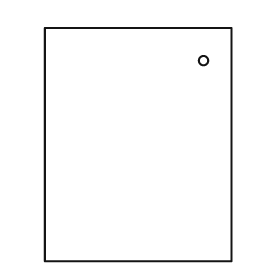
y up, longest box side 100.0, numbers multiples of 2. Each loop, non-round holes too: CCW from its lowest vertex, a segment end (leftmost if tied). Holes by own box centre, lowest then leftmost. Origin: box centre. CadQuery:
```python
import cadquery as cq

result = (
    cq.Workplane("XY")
    .moveTo(-40.0, -50.0)
    .lineTo(40.0, -50.0)
    .lineTo(40.0, 50.0)
    .lineTo(-40.0, 50.0)
    .close()
    .moveTo(28.0, 36.0)
    .circle(2.0)
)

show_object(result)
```